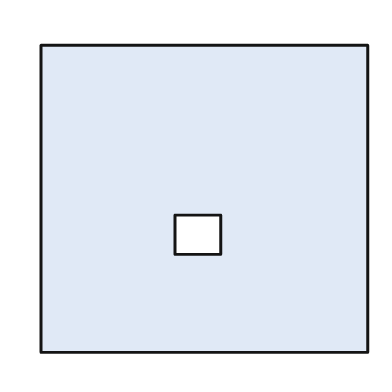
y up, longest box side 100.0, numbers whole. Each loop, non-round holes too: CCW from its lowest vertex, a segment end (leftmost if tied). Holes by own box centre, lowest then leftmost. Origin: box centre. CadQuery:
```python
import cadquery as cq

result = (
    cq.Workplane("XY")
    .moveTo(-50.0, -47.0)
    .lineTo(50.0, -47.0)
    .lineTo(50.0, 47.0)
    .lineTo(-50.0, 47.0)
    .close()
    .moveTo(-9.0, -17.0)
    .lineTo(5.0, -17.0)
    .lineTo(5.0, -5.0)
    .lineTo(-9.0, -5.0)
    .close()
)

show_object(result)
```